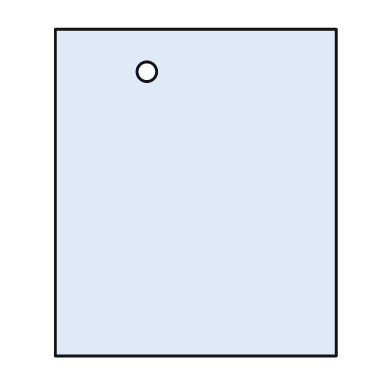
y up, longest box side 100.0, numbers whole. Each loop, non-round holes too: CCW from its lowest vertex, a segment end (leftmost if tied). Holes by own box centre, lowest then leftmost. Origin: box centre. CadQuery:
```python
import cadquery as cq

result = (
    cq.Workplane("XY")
    .moveTo(-43.0, -50.0)
    .lineTo(43.0, -50.0)
    .lineTo(43.0, 50.0)
    .lineTo(-43.0, 50.0)
    .close()
    .moveTo(-15.0, 37.0)
    .circle(3.0)
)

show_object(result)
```